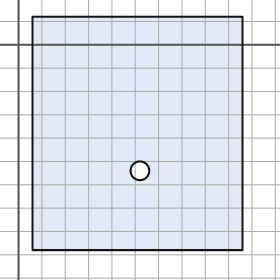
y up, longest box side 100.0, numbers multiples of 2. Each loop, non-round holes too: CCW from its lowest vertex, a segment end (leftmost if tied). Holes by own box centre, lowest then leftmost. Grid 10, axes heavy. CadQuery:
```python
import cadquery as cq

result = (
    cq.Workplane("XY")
    .moveTo(6.0, -88.0)
    .lineTo(96.0, -88.0)
    .lineTo(96.0, 12.0)
    .lineTo(6.0, 12.0)
    .close()
    .moveTo(52.0, -54.0)
    .circle(4.0)
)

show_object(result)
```